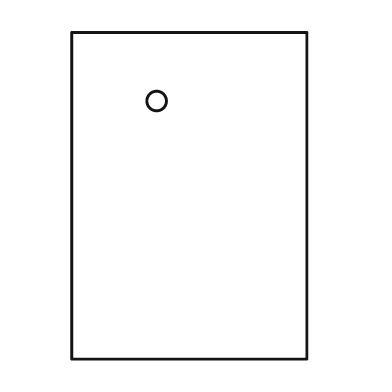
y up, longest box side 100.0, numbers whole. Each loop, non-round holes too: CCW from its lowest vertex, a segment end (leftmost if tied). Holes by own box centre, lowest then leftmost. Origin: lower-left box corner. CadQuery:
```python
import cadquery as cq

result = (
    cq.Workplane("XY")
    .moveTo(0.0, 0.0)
    .lineTo(72.0, 0.0)
    .lineTo(72.0, 100.0)
    .lineTo(0.0, 100.0)
    .close()
    .moveTo(26.0, 79.0)
    .circle(3.0)
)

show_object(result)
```